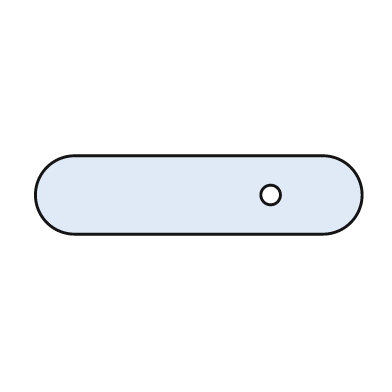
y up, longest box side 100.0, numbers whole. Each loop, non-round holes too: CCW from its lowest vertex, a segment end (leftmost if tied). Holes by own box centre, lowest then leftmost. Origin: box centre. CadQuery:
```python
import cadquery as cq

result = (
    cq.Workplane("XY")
    .moveTo(-38.0, -12.0)
    .lineTo(38.0, -12.0)
    .threePointArc((50.0, 0.0), (38.0, 12.0))
    .lineTo(-38.0, 12.0)
    .threePointArc((-50.0, 0.0), (-38.0, -12.0))
    .close()
    .moveTo(22.0, 0.0)
    .circle(3.0)
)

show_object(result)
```